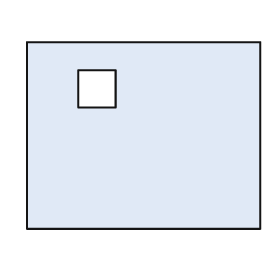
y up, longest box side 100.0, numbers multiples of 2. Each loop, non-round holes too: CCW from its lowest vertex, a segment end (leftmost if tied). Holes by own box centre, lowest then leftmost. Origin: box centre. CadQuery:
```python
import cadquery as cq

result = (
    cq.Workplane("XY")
    .moveTo(-50.0, -40.0)
    .lineTo(50.0, -40.0)
    .lineTo(50.0, 40.0)
    .lineTo(-50.0, 40.0)
    .close()
    .moveTo(-28.0, 12.0)
    .lineTo(-12.0, 12.0)
    .lineTo(-12.0, 28.0)
    .lineTo(-28.0, 28.0)
    .close()
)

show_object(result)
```